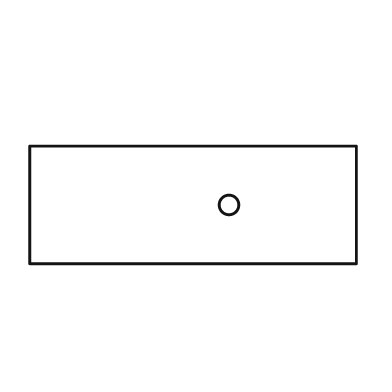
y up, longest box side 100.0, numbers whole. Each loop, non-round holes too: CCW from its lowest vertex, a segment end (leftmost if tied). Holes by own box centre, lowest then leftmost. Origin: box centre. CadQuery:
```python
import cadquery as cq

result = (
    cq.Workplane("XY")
    .moveTo(-50.0, -18.0)
    .lineTo(50.0, -18.0)
    .lineTo(50.0, 18.0)
    .lineTo(-50.0, 18.0)
    .close()
    .moveTo(11.0, 0.0)
    .circle(3.0)
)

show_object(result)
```